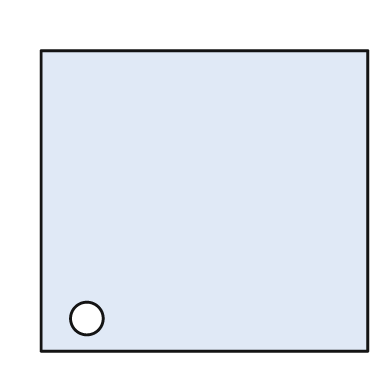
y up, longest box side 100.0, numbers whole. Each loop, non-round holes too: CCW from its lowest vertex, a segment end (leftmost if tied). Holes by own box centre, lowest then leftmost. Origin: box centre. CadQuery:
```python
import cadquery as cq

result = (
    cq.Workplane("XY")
    .moveTo(-50.0, -46.0)
    .lineTo(50.0, -46.0)
    .lineTo(50.0, 46.0)
    .lineTo(-50.0, 46.0)
    .close()
    .moveTo(-36.0, -36.0)
    .circle(5.0)
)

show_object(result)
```